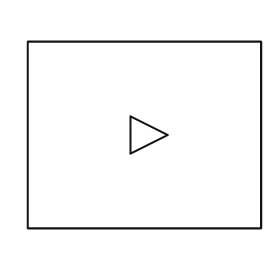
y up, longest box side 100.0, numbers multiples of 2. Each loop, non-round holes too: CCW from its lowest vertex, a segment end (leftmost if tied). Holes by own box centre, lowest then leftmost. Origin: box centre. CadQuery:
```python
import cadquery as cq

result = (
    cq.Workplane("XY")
    .moveTo(-50.0, -40.0)
    .lineTo(50.0, -40.0)
    .lineTo(50.0, 40.0)
    .lineTo(-50.0, 40.0)
    .close()
    .moveTo(-6.0, -8.0)
    .lineTo(10.0, 0.0)
    .lineTo(-6.0, 8.0)
    .close()
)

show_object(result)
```